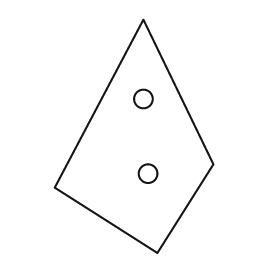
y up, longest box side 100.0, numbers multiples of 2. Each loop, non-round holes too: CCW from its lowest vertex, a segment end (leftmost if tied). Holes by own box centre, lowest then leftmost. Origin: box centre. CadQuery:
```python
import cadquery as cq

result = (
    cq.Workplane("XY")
    .moveTo(10.0, -50.0)
    .lineTo(34.0, -12.0)
    .lineTo(4.0, 50.0)
    .lineTo(-34.0, -22.0)
    .close()
    .moveTo(6.0, -16.0)
    .circle(4.0)
    .moveTo(4.0, 16.0)
    .circle(4.0)
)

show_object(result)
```